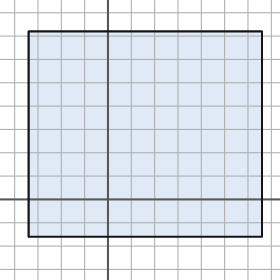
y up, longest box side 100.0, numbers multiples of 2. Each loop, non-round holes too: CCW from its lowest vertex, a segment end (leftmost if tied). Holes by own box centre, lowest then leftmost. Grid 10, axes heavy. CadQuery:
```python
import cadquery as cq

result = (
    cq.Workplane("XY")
    .moveTo(-34.0, -16.0)
    .lineTo(66.0, -16.0)
    .lineTo(66.0, 72.0)
    .lineTo(-34.0, 72.0)
    .close()
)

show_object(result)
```